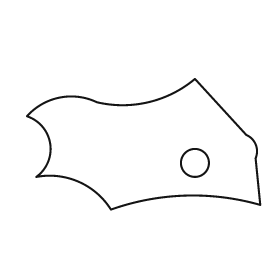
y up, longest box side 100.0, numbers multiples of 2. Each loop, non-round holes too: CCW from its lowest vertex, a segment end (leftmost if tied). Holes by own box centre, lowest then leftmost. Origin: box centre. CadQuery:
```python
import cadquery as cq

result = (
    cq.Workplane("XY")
    .moveTo(-14.0, -28.0)
    .threePointArc((18.0, -22.0), (50.0, -26.0))
    .lineTo(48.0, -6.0)
    .threePointArc((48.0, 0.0), (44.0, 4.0))
    .lineTo(22.0, 28.0)
    .threePointArc((2.0, 18.0), (-20.0, 18.0))
    .threePointArc((-36.0, 20.0), (-50.0, 12.0))
    .threePointArc((-40.0, 0.0), (-46.0, -14.0))
    .threePointArc((-28.0, -16.0), (-14.0, -28.0))
    .close()
    .moveTo(22.0, -8.0)
    .circle(6.0)
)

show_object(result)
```